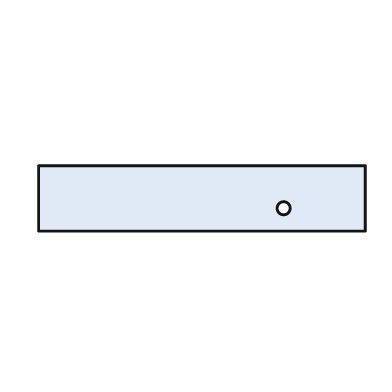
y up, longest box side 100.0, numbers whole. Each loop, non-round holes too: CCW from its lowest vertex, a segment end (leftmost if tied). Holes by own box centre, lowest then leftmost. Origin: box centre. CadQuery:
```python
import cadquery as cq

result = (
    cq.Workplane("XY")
    .moveTo(-50.0, -10.0)
    .lineTo(50.0, -10.0)
    .lineTo(50.0, 10.0)
    .lineTo(-50.0, 10.0)
    .close()
    .moveTo(25.0, -3.0)
    .circle(2.0)
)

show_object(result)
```